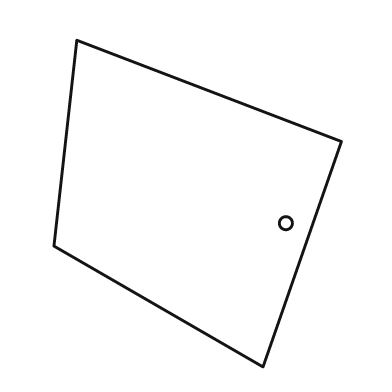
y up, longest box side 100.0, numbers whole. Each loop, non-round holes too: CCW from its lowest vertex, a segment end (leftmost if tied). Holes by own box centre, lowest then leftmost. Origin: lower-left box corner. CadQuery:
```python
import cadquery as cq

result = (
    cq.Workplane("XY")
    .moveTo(64.0, 0.0)
    .lineTo(88.0, 69.0)
    .lineTo(7.0, 100.0)
    .lineTo(0.0, 37.0)
    .close()
    .moveTo(71.0, 44.0)
    .circle(2.0)
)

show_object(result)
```